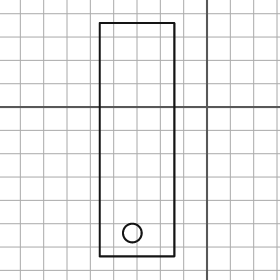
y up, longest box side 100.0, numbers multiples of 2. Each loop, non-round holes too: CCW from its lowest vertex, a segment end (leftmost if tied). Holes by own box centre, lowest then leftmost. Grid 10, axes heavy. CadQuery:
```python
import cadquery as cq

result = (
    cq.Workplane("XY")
    .moveTo(-46.0, -64.0)
    .lineTo(-14.0, -64.0)
    .lineTo(-14.0, 36.0)
    .lineTo(-46.0, 36.0)
    .close()
    .moveTo(-32.0, -54.0)
    .circle(4.0)
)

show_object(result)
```